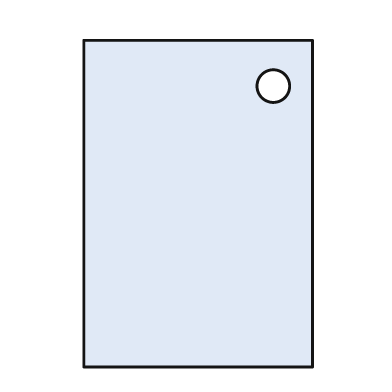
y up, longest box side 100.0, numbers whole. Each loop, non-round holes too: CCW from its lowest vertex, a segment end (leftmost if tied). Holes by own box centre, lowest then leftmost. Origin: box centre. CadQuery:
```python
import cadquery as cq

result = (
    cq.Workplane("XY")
    .moveTo(-35.0, -50.0)
    .lineTo(35.0, -50.0)
    .lineTo(35.0, 50.0)
    .lineTo(-35.0, 50.0)
    .close()
    .moveTo(23.0, 36.0)
    .circle(5.0)
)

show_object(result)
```